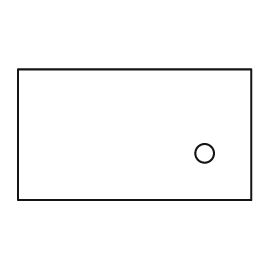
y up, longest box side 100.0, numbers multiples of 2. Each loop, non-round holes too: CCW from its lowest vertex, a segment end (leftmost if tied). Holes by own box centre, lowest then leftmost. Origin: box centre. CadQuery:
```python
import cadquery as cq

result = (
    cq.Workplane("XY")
    .moveTo(-50.0, -28.0)
    .lineTo(50.0, -28.0)
    .lineTo(50.0, 28.0)
    .lineTo(-50.0, 28.0)
    .close()
    .moveTo(30.0, -8.0)
    .circle(4.0)
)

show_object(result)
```